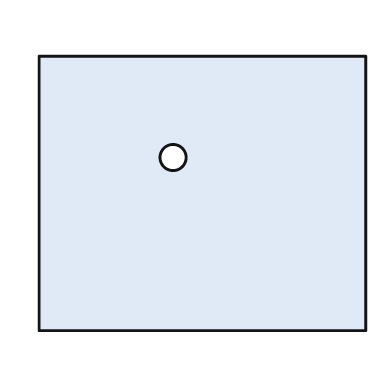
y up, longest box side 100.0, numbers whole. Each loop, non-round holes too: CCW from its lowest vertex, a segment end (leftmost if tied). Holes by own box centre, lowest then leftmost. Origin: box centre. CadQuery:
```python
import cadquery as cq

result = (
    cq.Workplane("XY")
    .moveTo(-50.0, -42.0)
    .lineTo(50.0, -42.0)
    .lineTo(50.0, 42.0)
    .lineTo(-50.0, 42.0)
    .close()
    .moveTo(-9.0, 11.0)
    .circle(4.0)
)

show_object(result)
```